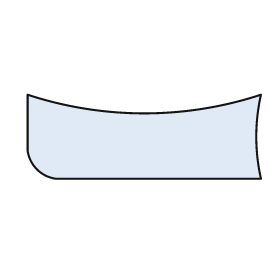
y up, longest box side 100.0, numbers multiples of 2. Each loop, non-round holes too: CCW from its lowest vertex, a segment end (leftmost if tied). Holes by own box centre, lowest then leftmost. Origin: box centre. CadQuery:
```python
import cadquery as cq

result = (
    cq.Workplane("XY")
    .moveTo(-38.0, -18.0)
    .lineTo(50.0, -18.0)
    .threePointArc((48.0, 0.0), (50.0, 18.0))
    .threePointArc((0.0, 10.0), (-50.0, 18.0))
    .lineTo(-50.0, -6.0)
    .threePointArc((-46.0, -14.0), (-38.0, -18.0))
    .close()
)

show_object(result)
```